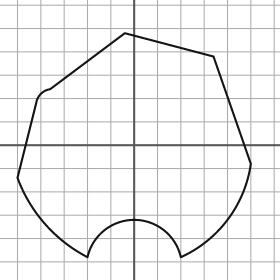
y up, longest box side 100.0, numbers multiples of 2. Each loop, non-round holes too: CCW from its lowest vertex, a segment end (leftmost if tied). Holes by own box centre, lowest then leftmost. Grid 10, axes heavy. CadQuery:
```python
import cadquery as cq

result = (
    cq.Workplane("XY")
    .moveTo(-20.0, -48.0)
    .threePointArc((0.0, -32.0), (20.0, -48.0))
    .threePointArc((40.0, -32.0), (50.0, -8.0))
    .lineTo(34.0, 38.0)
    .lineTo(-4.0, 48.0)
    .lineTo(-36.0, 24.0)
    .threePointArc((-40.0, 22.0), (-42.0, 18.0))
    .lineTo(-50.0, -14.0)
    .threePointArc((-38.0, -34.0), (-20.0, -48.0))
    .close()
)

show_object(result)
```